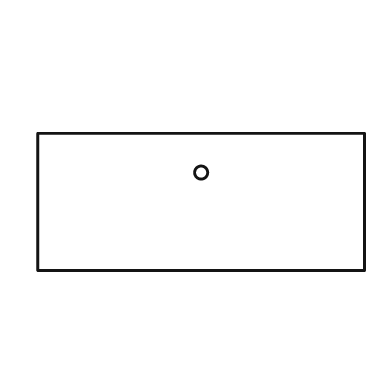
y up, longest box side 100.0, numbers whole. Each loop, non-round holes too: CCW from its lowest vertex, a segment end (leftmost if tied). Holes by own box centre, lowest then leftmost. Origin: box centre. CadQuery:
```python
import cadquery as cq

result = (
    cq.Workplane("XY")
    .moveTo(-50.0, -21.0)
    .lineTo(50.0, -21.0)
    .lineTo(50.0, 21.0)
    .lineTo(-50.0, 21.0)
    .close()
    .moveTo(0.0, 9.0)
    .circle(2.0)
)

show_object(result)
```